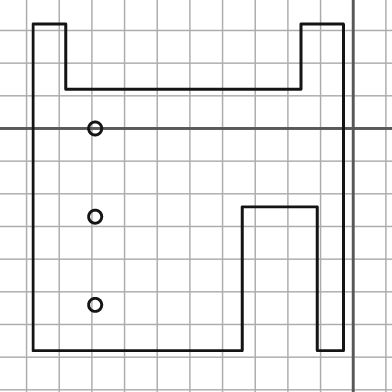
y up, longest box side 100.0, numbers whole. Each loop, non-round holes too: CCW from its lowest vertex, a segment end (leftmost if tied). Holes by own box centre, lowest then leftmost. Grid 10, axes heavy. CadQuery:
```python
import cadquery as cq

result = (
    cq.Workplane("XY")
    .moveTo(-98.0, -68.0)
    .lineTo(-34.0, -68.0)
    .lineTo(-34.0, -24.0)
    .lineTo(-11.0, -24.0)
    .lineTo(-11.0, -68.0)
    .lineTo(-3.0, -68.0)
    .lineTo(-3.0, 32.0)
    .lineTo(-16.0, 32.0)
    .lineTo(-16.0, 12.0)
    .lineTo(-88.0, 12.0)
    .lineTo(-88.0, 32.0)
    .lineTo(-98.0, 32.0)
    .close()
    .moveTo(-79.0, -54.0)
    .circle(2.0)
    .moveTo(-79.0, -27.0)
    .circle(2.0)
    .moveTo(-79.0, 0.0)
    .circle(2.0)
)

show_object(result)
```